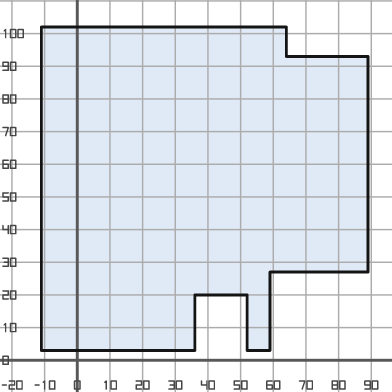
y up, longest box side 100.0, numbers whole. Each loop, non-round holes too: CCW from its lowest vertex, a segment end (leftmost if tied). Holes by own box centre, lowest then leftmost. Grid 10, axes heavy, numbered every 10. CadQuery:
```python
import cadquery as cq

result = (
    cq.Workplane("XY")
    .moveTo(-11.0, 3.0)
    .lineTo(36.0, 3.0)
    .lineTo(36.0, 20.0)
    .lineTo(52.0, 20.0)
    .lineTo(52.0, 3.0)
    .lineTo(59.0, 3.0)
    .lineTo(59.0, 27.0)
    .lineTo(89.0, 27.0)
    .lineTo(89.0, 93.0)
    .lineTo(64.0, 93.0)
    .lineTo(64.0, 102.0)
    .lineTo(-11.0, 102.0)
    .close()
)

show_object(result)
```